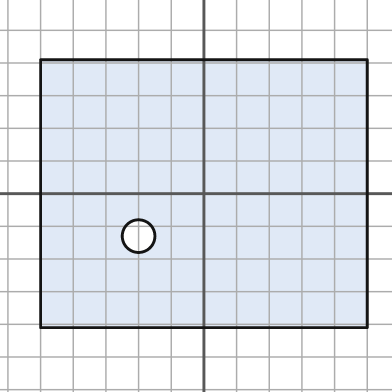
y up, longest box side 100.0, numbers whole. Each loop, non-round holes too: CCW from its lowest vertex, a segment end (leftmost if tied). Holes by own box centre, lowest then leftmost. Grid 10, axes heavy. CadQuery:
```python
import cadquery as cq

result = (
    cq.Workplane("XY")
    .moveTo(-50.0, -41.0)
    .lineTo(50.0, -41.0)
    .lineTo(50.0, 41.0)
    .lineTo(-50.0, 41.0)
    .close()
    .moveTo(-20.0, -13.0)
    .circle(5.0)
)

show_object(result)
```